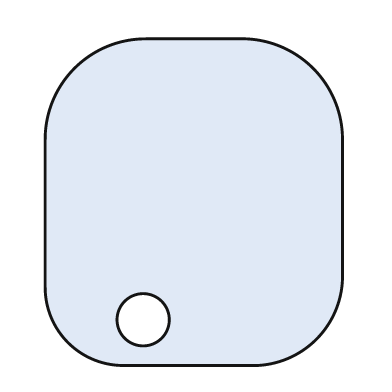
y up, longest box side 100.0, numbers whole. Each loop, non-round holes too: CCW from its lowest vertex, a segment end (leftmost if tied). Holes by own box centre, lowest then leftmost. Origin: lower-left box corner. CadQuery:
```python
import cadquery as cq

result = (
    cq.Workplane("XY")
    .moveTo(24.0, 0.0)
    .lineTo(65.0, 0.0)
    .threePointArc((83.0, 8.0), (91.0, 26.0))
    .lineTo(91.0, 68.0)
    .threePointArc((82.0, 91.0), (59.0, 100.0))
    .lineTo(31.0, 100.0)
    .threePointArc((9.0, 91.0), (0.0, 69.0))
    .lineTo(0.0, 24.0)
    .threePointArc((7.0, 7.0), (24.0, 0.0))
    .close()
    .moveTo(30.0, 14.0)
    .circle(8.0)
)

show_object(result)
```